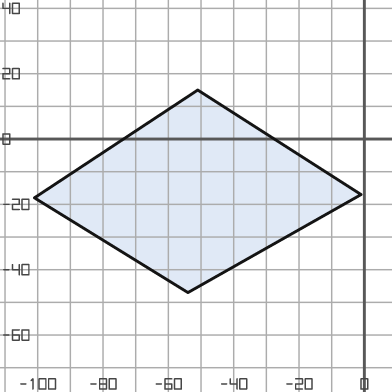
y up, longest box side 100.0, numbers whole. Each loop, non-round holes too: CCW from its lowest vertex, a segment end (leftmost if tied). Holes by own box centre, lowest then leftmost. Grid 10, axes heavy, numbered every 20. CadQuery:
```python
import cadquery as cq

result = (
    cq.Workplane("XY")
    .moveTo(-54.0, -47.0)
    .lineTo(-1.0, -17.0)
    .lineTo(-51.0, 15.0)
    .lineTo(-101.0, -18.0)
    .close()
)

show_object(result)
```